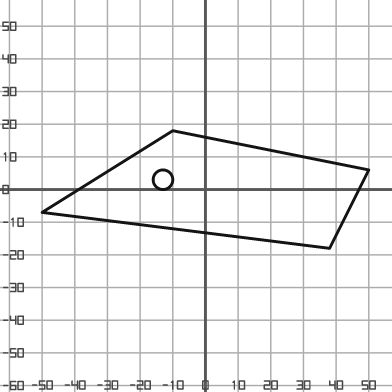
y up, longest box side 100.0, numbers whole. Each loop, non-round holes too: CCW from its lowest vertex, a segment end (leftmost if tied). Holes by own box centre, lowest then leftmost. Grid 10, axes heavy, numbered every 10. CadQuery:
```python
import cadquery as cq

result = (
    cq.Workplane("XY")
    .moveTo(38.0, -18.0)
    .lineTo(50.0, 6.0)
    .lineTo(-10.0, 18.0)
    .lineTo(-50.0, -7.0)
    .close()
    .moveTo(-13.0, 3.0)
    .circle(3.0)
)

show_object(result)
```